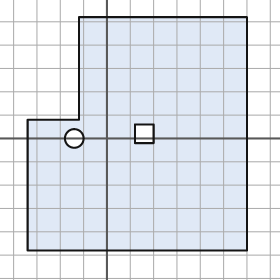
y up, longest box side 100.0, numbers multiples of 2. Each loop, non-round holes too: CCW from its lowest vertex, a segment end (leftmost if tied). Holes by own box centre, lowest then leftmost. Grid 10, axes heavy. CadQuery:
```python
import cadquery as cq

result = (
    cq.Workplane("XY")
    .moveTo(-34.0, -48.0)
    .lineTo(60.0, -48.0)
    .lineTo(60.0, 52.0)
    .lineTo(-12.0, 52.0)
    .lineTo(-12.0, 8.0)
    .lineTo(-34.0, 8.0)
    .close()
    .moveTo(-14.0, 0.0)
    .circle(4.0)
    .moveTo(12.0, -2.0)
    .lineTo(20.0, -2.0)
    .lineTo(20.0, 6.0)
    .lineTo(12.0, 6.0)
    .close()
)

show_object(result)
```